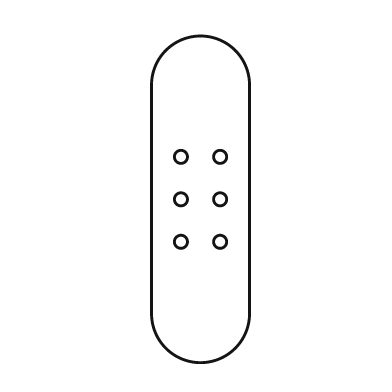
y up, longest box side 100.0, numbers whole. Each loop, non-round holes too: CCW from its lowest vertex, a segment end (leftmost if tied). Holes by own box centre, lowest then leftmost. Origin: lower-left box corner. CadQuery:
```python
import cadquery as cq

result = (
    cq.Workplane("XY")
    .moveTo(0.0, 15.0)
    .threePointArc((15.0, 0.0), (30.0, 15.0))
    .lineTo(30.0, 85.0)
    .threePointArc((15.0, 100.0), (0.0, 85.0))
    .close()
    .moveTo(9.0, 37.0)
    .circle(2.0)
    .moveTo(21.0, 37.0)
    .circle(2.0)
    .moveTo(9.0, 50.0)
    .circle(2.0)
    .moveTo(21.0, 50.0)
    .circle(2.0)
    .moveTo(9.0, 63.0)
    .circle(2.0)
    .moveTo(21.0, 63.0)
    .circle(2.0)
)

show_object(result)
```